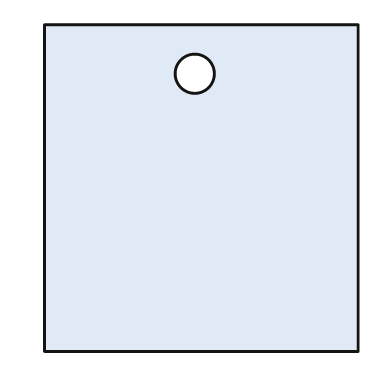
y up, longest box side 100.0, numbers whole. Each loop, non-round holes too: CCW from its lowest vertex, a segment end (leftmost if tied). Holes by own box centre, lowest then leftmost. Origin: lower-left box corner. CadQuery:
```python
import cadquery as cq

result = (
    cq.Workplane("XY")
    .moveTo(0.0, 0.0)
    .lineTo(96.0, 0.0)
    .lineTo(96.0, 100.0)
    .lineTo(0.0, 100.0)
    .close()
    .moveTo(46.0, 85.0)
    .circle(6.0)
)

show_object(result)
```